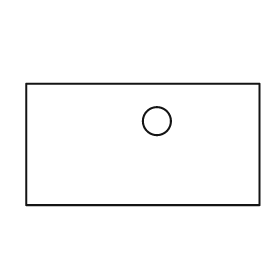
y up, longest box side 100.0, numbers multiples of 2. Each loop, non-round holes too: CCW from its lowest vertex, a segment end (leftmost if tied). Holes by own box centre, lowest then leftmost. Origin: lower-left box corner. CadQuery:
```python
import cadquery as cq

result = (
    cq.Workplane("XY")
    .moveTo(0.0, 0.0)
    .lineTo(100.0, 0.0)
    .lineTo(100.0, 52.0)
    .lineTo(0.0, 52.0)
    .close()
    .moveTo(56.0, 36.0)
    .circle(6.0)
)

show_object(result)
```